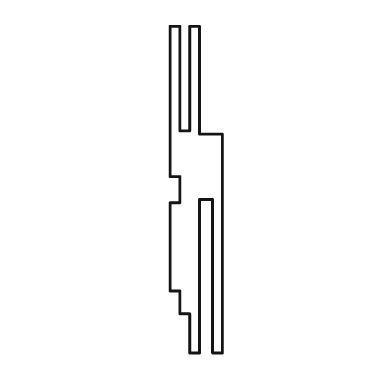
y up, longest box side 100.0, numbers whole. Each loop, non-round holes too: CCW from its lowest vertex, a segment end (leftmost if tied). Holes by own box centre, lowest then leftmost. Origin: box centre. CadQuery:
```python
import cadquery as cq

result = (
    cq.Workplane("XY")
    .moveTo(-2.0, -50.0)
    .lineTo(1.0, -50.0)
    .lineTo(1.0, -3.0)
    .lineTo(5.0, -3.0)
    .lineTo(5.0, -50.0)
    .lineTo(8.0, -50.0)
    .lineTo(8.0, 17.0)
    .lineTo(1.0, 17.0)
    .lineTo(1.0, 50.0)
    .lineTo(-2.0, 50.0)
    .lineTo(-2.0, 18.0)
    .lineTo(-5.0, 18.0)
    .lineTo(-5.0, 50.0)
    .lineTo(-8.0, 50.0)
    .lineTo(-8.0, 4.0)
    .lineTo(-5.0, 4.0)
    .lineTo(-5.0, -4.0)
    .lineTo(-8.0, -4.0)
    .lineTo(-8.0, -31.0)
    .lineTo(-5.0, -31.0)
    .lineTo(-5.0, -38.0)
    .lineTo(-2.0, -38.0)
    .close()
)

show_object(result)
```